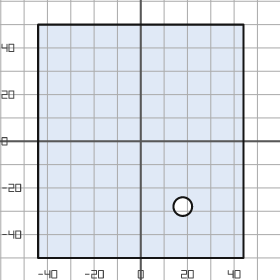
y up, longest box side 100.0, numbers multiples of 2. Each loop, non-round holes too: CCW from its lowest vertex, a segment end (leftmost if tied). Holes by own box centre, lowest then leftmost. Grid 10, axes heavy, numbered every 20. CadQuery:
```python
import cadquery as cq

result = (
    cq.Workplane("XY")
    .moveTo(-44.0, -50.0)
    .lineTo(44.0, -50.0)
    .lineTo(44.0, 50.0)
    .lineTo(-44.0, 50.0)
    .close()
    .moveTo(18.0, -28.0)
    .circle(4.0)
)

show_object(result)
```